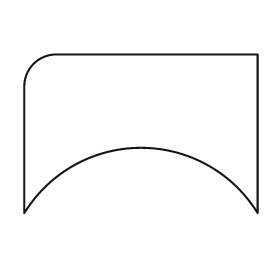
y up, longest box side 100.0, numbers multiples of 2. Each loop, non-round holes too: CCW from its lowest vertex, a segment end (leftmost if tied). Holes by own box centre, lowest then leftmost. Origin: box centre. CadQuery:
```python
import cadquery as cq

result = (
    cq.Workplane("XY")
    .moveTo(-50.0, -34.0)
    .threePointArc((0.0, -6.0), (50.0, -34.0))
    .lineTo(50.0, 34.0)
    .lineTo(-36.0, 34.0)
    .threePointArc((-46.0, 30.0), (-50.0, 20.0))
    .close()
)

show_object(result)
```